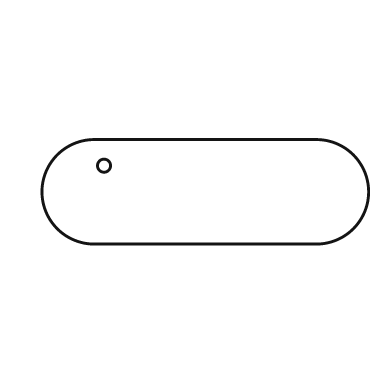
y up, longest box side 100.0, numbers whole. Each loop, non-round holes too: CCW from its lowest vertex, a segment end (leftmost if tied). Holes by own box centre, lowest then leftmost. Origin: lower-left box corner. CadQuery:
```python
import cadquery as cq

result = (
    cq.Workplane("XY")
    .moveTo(16.0, 0.0)
    .lineTo(84.0, 0.0)
    .threePointArc((100.0, 16.0), (84.0, 32.0))
    .lineTo(16.0, 32.0)
    .threePointArc((0.0, 16.0), (16.0, 0.0))
    .close()
    .moveTo(19.0, 24.0)
    .circle(2.0)
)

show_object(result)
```